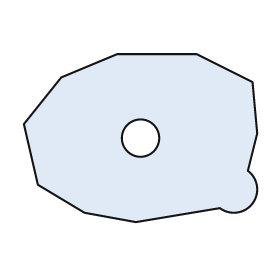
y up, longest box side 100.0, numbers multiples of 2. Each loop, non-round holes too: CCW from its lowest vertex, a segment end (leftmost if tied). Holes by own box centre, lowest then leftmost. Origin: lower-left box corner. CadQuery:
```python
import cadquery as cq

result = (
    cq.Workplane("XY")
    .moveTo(48.0, 0.0)
    .lineTo(84.0, 6.0)
    .threePointArc((98.0, 8.0), (96.0, 22.0))
    .lineTo(100.0, 38.0)
    .lineTo(98.0, 60.0)
    .lineTo(74.0, 72.0)
    .lineTo(40.0, 72.0)
    .lineTo(16.0, 62.0)
    .lineTo(0.0, 42.0)
    .lineTo(6.0, 16.0)
    .lineTo(26.0, 4.0)
    .close()
    .moveTo(50.0, 36.0)
    .circle(8.0)
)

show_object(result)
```